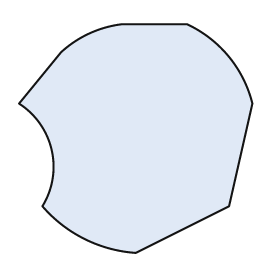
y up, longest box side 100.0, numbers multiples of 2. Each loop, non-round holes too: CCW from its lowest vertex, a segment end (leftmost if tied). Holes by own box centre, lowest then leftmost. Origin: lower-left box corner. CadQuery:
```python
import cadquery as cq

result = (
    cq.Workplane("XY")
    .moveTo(50.0, 0.0)
    .lineTo(90.0, 20.0)
    .lineTo(100.0, 64.0)
    .threePointArc((90.0, 84.0), (72.0, 98.0))
    .lineTo(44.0, 98.0)
    .threePointArc((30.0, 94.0), (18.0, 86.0))
    .lineTo(0.0, 64.0)
    .threePointArc((14.0, 44.0), (10.0, 20.0))
    .threePointArc((28.0, 6.0), (50.0, 0.0))
    .close()
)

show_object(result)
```